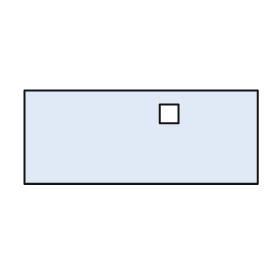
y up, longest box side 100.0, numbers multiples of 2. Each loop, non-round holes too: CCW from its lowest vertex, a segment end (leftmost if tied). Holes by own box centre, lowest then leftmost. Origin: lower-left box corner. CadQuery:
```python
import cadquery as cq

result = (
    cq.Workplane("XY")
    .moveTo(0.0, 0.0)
    .lineTo(100.0, 0.0)
    .lineTo(100.0, 40.0)
    .lineTo(0.0, 40.0)
    .close()
    .moveTo(58.0, 26.0)
    .lineTo(66.0, 26.0)
    .lineTo(66.0, 34.0)
    .lineTo(58.0, 34.0)
    .close()
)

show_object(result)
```